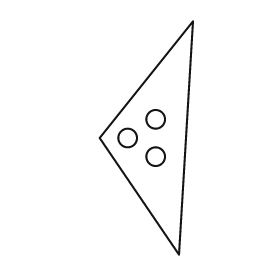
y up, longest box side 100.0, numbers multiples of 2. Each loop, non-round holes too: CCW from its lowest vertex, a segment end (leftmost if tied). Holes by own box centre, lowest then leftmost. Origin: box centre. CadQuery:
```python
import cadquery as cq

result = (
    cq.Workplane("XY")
    .moveTo(14.0, -50.0)
    .lineTo(20.0, 50.0)
    .lineTo(-20.0, 0.0)
    .close()
    .moveTo(4.0, -8.0)
    .circle(4.0)
    .moveTo(-8.0, 0.0)
    .circle(4.0)
    .moveTo(4.0, 8.0)
    .circle(4.0)
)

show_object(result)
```